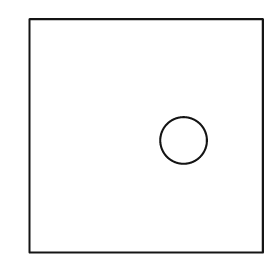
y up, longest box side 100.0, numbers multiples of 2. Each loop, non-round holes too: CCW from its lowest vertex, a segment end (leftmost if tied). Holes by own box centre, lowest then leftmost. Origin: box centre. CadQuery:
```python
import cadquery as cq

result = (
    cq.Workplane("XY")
    .moveTo(-50.0, -50.0)
    .lineTo(50.0, -50.0)
    .lineTo(50.0, 50.0)
    .lineTo(-50.0, 50.0)
    .close()
    .moveTo(16.0, -2.0)
    .circle(10.0)
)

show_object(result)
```